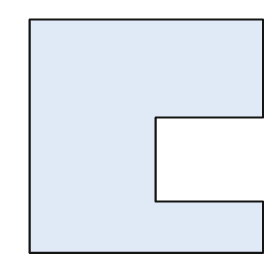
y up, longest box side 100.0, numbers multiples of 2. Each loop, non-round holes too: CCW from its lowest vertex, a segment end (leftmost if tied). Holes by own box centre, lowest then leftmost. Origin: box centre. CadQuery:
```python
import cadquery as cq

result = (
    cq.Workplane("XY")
    .moveTo(-50.0, -50.0)
    .lineTo(50.0, -50.0)
    .lineTo(50.0, -28.0)
    .lineTo(4.0, -28.0)
    .lineTo(4.0, 8.0)
    .lineTo(50.0, 8.0)
    .lineTo(50.0, 50.0)
    .lineTo(-50.0, 50.0)
    .close()
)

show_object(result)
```